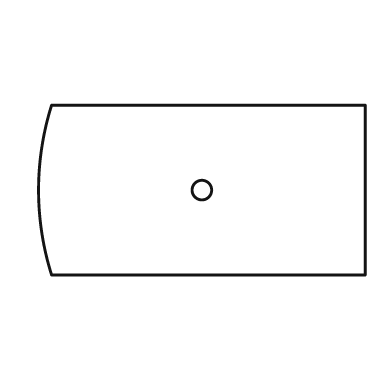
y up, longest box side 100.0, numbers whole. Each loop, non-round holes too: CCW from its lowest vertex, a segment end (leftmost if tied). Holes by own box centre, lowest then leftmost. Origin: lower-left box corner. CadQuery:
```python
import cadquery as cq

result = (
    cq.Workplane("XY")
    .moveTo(4.0, 0.0)
    .lineTo(100.0, 0.0)
    .lineTo(100.0, 52.0)
    .lineTo(4.0, 52.0)
    .threePointArc((0.0, 26.0), (4.0, 0.0))
    .close()
    .moveTo(50.0, 26.0)
    .circle(3.0)
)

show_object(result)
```